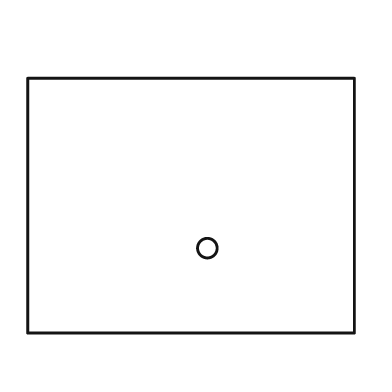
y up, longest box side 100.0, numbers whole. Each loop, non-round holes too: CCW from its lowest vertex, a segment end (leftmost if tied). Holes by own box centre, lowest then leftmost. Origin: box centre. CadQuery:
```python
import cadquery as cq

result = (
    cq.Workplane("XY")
    .moveTo(-50.0, -39.0)
    .lineTo(50.0, -39.0)
    .lineTo(50.0, 39.0)
    .lineTo(-50.0, 39.0)
    .close()
    .moveTo(5.0, -13.0)
    .circle(3.0)
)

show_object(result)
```